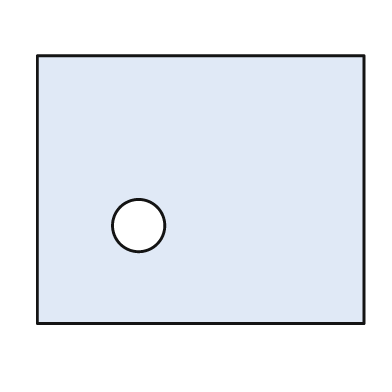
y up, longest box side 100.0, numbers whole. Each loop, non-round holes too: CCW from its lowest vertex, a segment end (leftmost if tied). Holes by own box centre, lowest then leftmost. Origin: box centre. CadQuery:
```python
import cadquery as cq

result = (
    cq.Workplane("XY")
    .moveTo(-50.0, -41.0)
    .lineTo(50.0, -41.0)
    .lineTo(50.0, 41.0)
    .lineTo(-50.0, 41.0)
    .close()
    .moveTo(-19.0, -11.0)
    .circle(8.0)
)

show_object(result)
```